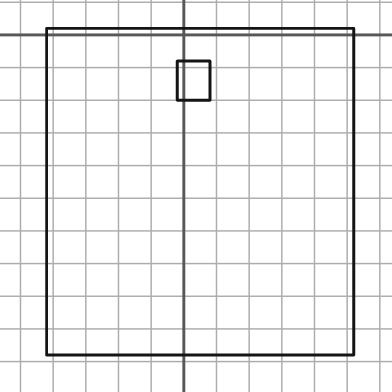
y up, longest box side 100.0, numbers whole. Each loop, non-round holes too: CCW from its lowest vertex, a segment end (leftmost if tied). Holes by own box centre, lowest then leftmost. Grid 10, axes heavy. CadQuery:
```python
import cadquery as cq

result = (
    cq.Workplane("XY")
    .moveTo(-42.0, -98.0)
    .lineTo(52.0, -98.0)
    .lineTo(52.0, 2.0)
    .lineTo(-42.0, 2.0)
    .close()
    .moveTo(-2.0, -20.0)
    .lineTo(8.0, -20.0)
    .lineTo(8.0, -8.0)
    .lineTo(-2.0, -8.0)
    .close()
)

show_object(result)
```